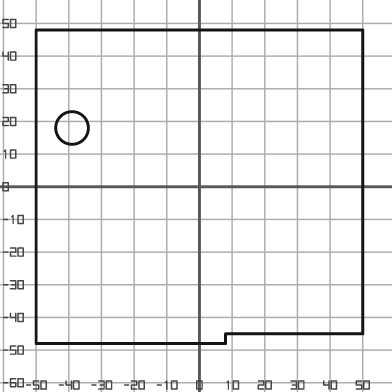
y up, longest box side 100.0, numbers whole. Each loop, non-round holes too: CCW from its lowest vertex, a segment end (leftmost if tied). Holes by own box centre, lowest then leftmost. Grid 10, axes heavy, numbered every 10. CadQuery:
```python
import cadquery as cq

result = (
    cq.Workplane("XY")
    .moveTo(-50.0, -48.0)
    .lineTo(8.0, -48.0)
    .lineTo(8.0, -45.0)
    .lineTo(50.0, -45.0)
    .lineTo(50.0, 48.0)
    .lineTo(-50.0, 48.0)
    .close()
    .moveTo(-39.0, 18.0)
    .circle(5.0)
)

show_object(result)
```